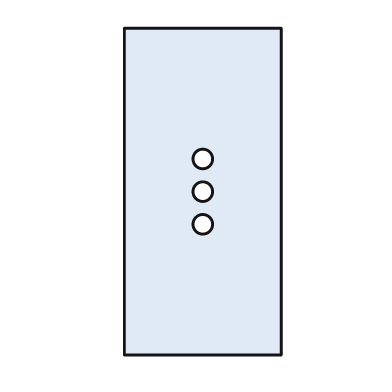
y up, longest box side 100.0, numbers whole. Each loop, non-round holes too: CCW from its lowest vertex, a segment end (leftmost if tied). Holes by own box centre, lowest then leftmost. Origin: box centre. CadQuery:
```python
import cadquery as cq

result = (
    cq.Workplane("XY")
    .moveTo(-24.0, -50.0)
    .lineTo(24.0, -50.0)
    .lineTo(24.0, 50.0)
    .lineTo(-24.0, 50.0)
    .close()
    .moveTo(0.0, -10.0)
    .circle(3.0)
    .moveTo(0.0, 0.0)
    .circle(3.0)
    .moveTo(0.0, 10.0)
    .circle(3.0)
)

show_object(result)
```